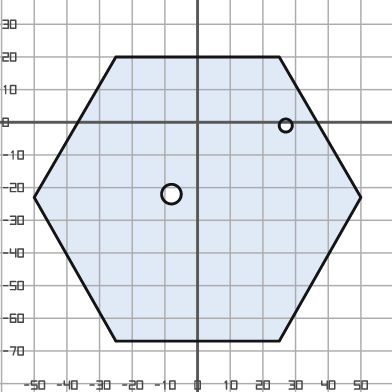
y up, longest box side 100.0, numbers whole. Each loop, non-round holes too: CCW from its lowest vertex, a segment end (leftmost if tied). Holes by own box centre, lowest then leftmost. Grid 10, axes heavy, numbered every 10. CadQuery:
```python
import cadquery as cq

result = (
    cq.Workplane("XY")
    .moveTo(-25.0, -67.0)
    .lineTo(25.0, -67.0)
    .lineTo(50.0, -23.0)
    .lineTo(25.0, 20.0)
    .lineTo(-25.0, 20.0)
    .lineTo(-50.0, -23.0)
    .close()
    .moveTo(-8.0, -22.0)
    .circle(3.0)
    .moveTo(27.0, -1.0)
    .circle(2.0)
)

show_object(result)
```